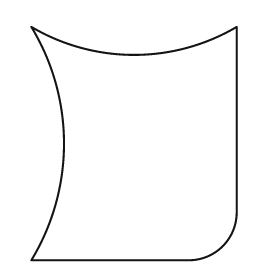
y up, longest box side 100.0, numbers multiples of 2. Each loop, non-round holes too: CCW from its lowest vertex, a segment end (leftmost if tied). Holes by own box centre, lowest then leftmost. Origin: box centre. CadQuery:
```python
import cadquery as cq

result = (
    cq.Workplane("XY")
    .moveTo(-44.0, -50.0)
    .lineTo(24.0, -50.0)
    .threePointArc((38.0, -44.0), (44.0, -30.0))
    .lineTo(44.0, 50.0)
    .threePointArc((0.0, 38.0), (-44.0, 50.0))
    .threePointArc((-30.0, 0.0), (-44.0, -50.0))
    .close()
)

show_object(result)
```